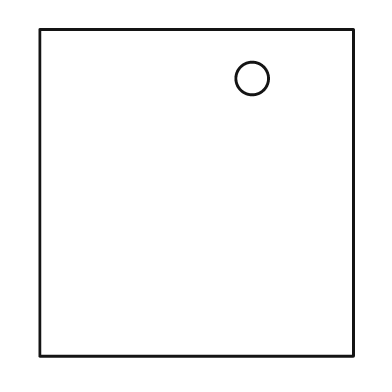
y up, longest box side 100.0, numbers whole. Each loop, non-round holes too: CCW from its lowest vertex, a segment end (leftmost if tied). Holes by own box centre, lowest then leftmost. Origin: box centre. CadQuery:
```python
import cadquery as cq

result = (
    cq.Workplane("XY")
    .moveTo(-48.0, -50.0)
    .lineTo(48.0, -50.0)
    .lineTo(48.0, 50.0)
    .lineTo(-48.0, 50.0)
    .close()
    .moveTo(17.0, 35.0)
    .circle(5.0)
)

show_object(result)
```